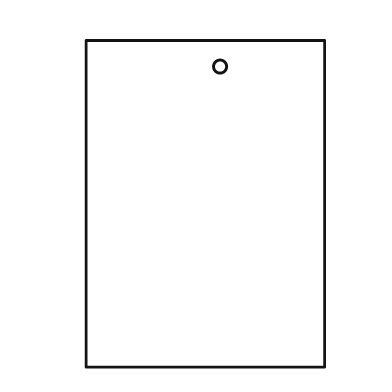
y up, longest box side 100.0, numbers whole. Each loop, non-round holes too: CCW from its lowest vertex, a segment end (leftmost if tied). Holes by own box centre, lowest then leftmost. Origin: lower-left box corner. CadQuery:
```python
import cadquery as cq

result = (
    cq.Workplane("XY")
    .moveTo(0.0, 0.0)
    .lineTo(73.0, 0.0)
    .lineTo(73.0, 100.0)
    .lineTo(0.0, 100.0)
    .close()
    .moveTo(41.0, 92.0)
    .circle(2.0)
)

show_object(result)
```